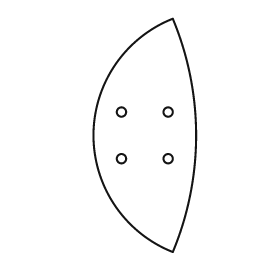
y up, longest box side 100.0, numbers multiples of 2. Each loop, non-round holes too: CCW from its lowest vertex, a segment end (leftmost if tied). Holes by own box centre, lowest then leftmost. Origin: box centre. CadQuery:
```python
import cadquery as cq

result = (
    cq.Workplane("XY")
    .moveTo(12.0, -50.0)
    .threePointArc((22.0, 0.0), (12.0, 50.0))
    .threePointArc((-22.0, 0.0), (12.0, -50.0))
    .close()
    .moveTo(-10.0, -10.0)
    .circle(2.0)
    .moveTo(10.0, -10.0)
    .circle(2.0)
    .moveTo(-10.0, 10.0)
    .circle(2.0)
    .moveTo(10.0, 10.0)
    .circle(2.0)
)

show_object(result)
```